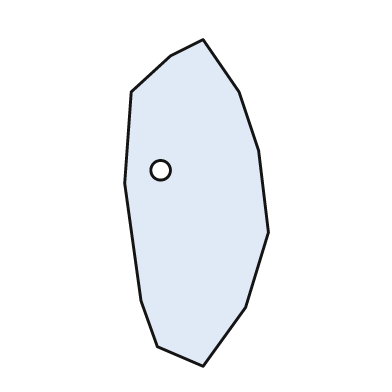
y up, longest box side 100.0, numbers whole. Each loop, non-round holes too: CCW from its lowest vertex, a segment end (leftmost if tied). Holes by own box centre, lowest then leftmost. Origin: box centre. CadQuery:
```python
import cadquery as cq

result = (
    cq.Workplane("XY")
    .moveTo(2.0, -50.0)
    .lineTo(15.0, -32.0)
    .lineTo(22.0, -9.0)
    .lineTo(19.0, 16.0)
    .lineTo(13.0, 34.0)
    .lineTo(2.0, 50.0)
    .lineTo(-8.0, 45.0)
    .lineTo(-20.0, 34.0)
    .lineTo(-22.0, 6.0)
    .lineTo(-17.0, -30.0)
    .lineTo(-12.0, -44.0)
    .close()
    .moveTo(-11.0, 10.0)
    .circle(3.0)
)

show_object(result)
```